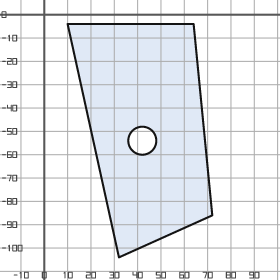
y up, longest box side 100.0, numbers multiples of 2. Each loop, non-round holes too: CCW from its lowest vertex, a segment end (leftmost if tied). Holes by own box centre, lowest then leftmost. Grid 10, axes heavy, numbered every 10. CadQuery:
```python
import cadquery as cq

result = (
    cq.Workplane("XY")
    .moveTo(32.0, -104.0)
    .lineTo(72.0, -86.0)
    .lineTo(64.0, -4.0)
    .lineTo(10.0, -4.0)
    .close()
    .moveTo(42.0, -54.0)
    .circle(6.0)
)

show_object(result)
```